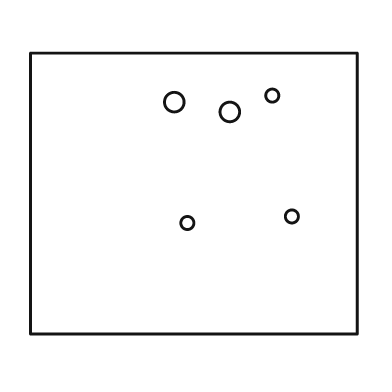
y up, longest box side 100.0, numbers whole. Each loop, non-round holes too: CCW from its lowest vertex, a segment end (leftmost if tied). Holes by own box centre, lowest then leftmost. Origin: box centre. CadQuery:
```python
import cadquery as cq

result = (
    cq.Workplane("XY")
    .moveTo(-50.0, -43.0)
    .lineTo(50.0, -43.0)
    .lineTo(50.0, 43.0)
    .lineTo(-50.0, 43.0)
    .close()
    .moveTo(-2.0, -9.0)
    .circle(2.0)
    .moveTo(30.0, -7.0)
    .circle(2.0)
    .moveTo(11.0, 25.0)
    .circle(3.0)
    .moveTo(-6.0, 28.0)
    .circle(3.0)
    .moveTo(24.0, 30.0)
    .circle(2.0)
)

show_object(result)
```